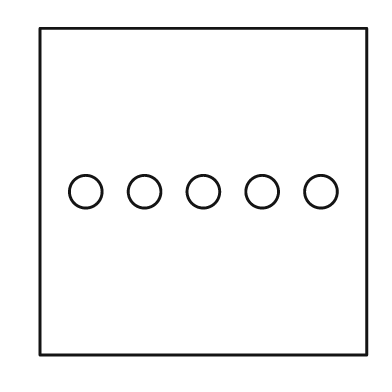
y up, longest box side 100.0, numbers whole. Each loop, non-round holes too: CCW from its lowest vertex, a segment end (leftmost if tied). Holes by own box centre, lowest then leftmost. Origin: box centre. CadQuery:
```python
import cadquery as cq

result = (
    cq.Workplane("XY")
    .moveTo(-50.0, -50.0)
    .lineTo(50.0, -50.0)
    .lineTo(50.0, 50.0)
    .lineTo(-50.0, 50.0)
    .close()
    .moveTo(-36.0, 0.0)
    .circle(5.0)
    .moveTo(-18.0, 0.0)
    .circle(5.0)
    .moveTo(0.0, 0.0)
    .circle(5.0)
    .moveTo(18.0, 0.0)
    .circle(5.0)
    .moveTo(36.0, 0.0)
    .circle(5.0)
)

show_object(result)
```